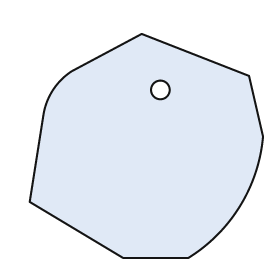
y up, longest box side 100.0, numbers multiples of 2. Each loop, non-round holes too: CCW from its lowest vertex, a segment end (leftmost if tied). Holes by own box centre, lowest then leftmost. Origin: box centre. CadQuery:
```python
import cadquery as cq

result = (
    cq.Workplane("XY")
    .moveTo(-10.0, -48.0)
    .lineTo(18.0, -48.0)
    .threePointArc((40.0, -26.0), (50.0, 4.0))
    .lineTo(44.0, 30.0)
    .lineTo(-2.0, 48.0)
    .lineTo(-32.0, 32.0)
    .threePointArc((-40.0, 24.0), (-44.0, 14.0))
    .lineTo(-50.0, -24.0)
    .close()
    .moveTo(6.0, 24.0)
    .circle(4.0)
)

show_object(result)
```